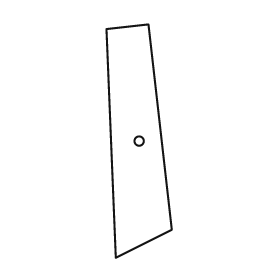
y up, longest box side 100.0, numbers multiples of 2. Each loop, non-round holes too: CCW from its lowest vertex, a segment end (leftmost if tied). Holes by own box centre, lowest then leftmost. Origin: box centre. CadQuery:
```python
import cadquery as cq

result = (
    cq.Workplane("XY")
    .moveTo(-10.0, -50.0)
    .lineTo(14.0, -38.0)
    .lineTo(4.0, 50.0)
    .lineTo(-14.0, 48.0)
    .close()
    .moveTo(0.0, 0.0)
    .circle(2.0)
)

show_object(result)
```